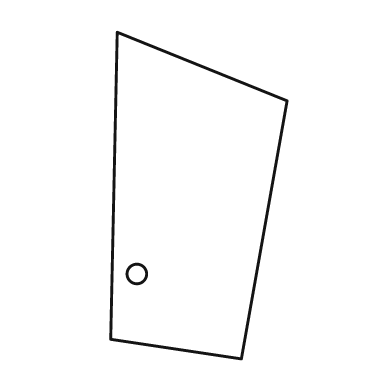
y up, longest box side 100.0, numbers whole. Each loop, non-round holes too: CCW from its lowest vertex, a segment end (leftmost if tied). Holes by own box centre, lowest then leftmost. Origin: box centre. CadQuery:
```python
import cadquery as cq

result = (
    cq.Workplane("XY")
    .moveTo(13.0, -50.0)
    .lineTo(27.0, 29.0)
    .lineTo(-25.0, 50.0)
    .lineTo(-27.0, -44.0)
    .close()
    .moveTo(-19.0, -24.0)
    .circle(3.0)
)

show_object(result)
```